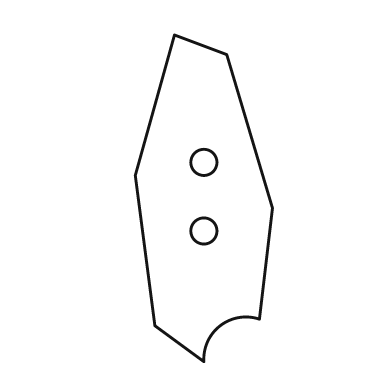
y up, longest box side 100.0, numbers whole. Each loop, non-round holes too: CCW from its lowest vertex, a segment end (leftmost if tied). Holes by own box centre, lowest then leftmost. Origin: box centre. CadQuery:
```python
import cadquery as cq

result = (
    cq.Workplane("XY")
    .moveTo(0.0, -50.0)
    .threePointArc((5.0, -39.0), (17.0, -37.0))
    .lineTo(21.0, -3.0)
    .lineTo(7.0, 44.0)
    .lineTo(-9.0, 50.0)
    .lineTo(-21.0, 7.0)
    .lineTo(-15.0, -39.0)
    .close()
    .moveTo(0.0, -10.0)
    .circle(4.0)
    .moveTo(0.0, 11.0)
    .circle(4.0)
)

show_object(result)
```